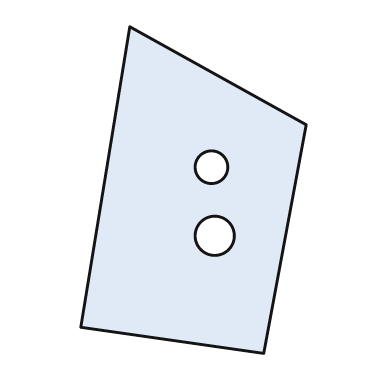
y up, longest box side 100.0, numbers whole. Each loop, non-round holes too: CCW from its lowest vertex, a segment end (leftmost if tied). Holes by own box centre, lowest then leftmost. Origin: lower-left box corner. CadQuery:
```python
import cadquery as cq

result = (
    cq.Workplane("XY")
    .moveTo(56.0, 0.0)
    .lineTo(69.0, 70.0)
    .lineTo(15.0, 100.0)
    .lineTo(0.0, 8.0)
    .close()
    .moveTo(41.0, 36.0)
    .circle(6.0)
    .moveTo(40.0, 57.0)
    .circle(5.0)
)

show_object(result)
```